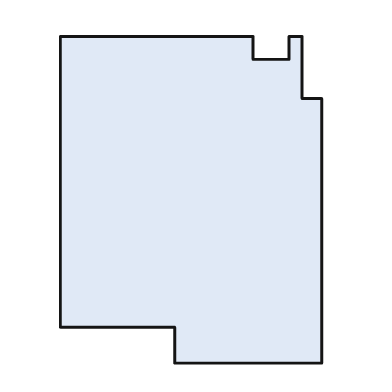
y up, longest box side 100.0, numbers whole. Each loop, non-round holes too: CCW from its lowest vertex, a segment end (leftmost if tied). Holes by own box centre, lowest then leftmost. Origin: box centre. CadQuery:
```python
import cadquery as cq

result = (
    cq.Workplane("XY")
    .moveTo(-5.0, -50.0)
    .lineTo(40.0, -50.0)
    .lineTo(40.0, 31.0)
    .lineTo(34.0, 31.0)
    .lineTo(34.0, 50.0)
    .lineTo(30.0, 50.0)
    .lineTo(30.0, 43.0)
    .lineTo(19.0, 43.0)
    .lineTo(19.0, 50.0)
    .lineTo(-40.0, 50.0)
    .lineTo(-40.0, -39.0)
    .lineTo(-5.0, -39.0)
    .close()
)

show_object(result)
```